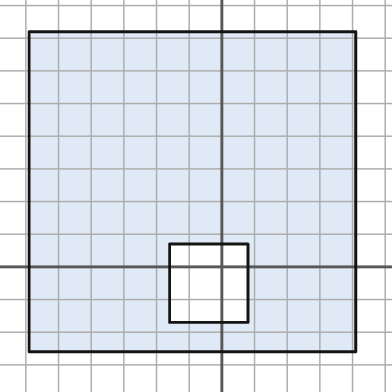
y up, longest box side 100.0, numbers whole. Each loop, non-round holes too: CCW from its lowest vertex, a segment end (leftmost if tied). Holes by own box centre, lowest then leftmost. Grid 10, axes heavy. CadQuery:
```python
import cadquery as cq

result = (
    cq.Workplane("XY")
    .moveTo(-59.0, -26.0)
    .lineTo(41.0, -26.0)
    .lineTo(41.0, 72.0)
    .lineTo(-59.0, 72.0)
    .close()
    .moveTo(-16.0, -17.0)
    .lineTo(8.0, -17.0)
    .lineTo(8.0, 7.0)
    .lineTo(-16.0, 7.0)
    .close()
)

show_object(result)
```